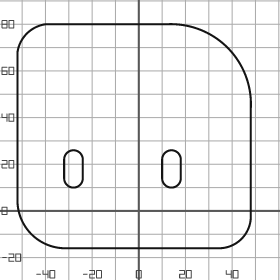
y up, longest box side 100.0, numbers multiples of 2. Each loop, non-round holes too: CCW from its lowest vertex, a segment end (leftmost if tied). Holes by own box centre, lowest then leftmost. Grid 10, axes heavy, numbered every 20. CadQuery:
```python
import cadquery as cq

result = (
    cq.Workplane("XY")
    .moveTo(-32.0, -16.0)
    .lineTo(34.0, -16.0)
    .threePointArc((44.0, -12.0), (48.0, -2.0))
    .lineTo(48.0, 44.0)
    .threePointArc((38.0, 70.0), (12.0, 80.0))
    .lineTo(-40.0, 80.0)
    .threePointArc((-48.0, 76.0), (-52.0, 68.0))
    .lineTo(-52.0, 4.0)
    .threePointArc((-46.0, -10.0), (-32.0, -16.0))
    .close()
    .moveTo(-32.0, 14.0)
    .threePointArc((-28.0, 10.0), (-24.0, 14.0))
    .lineTo(-24.0, 22.0)
    .threePointArc((-28.0, 26.0), (-32.0, 22.0))
    .close()
    .moveTo(10.0, 14.0)
    .threePointArc((14.0, 10.0), (18.0, 14.0))
    .lineTo(18.0, 22.0)
    .threePointArc((14.0, 26.0), (10.0, 22.0))
    .close()
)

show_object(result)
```